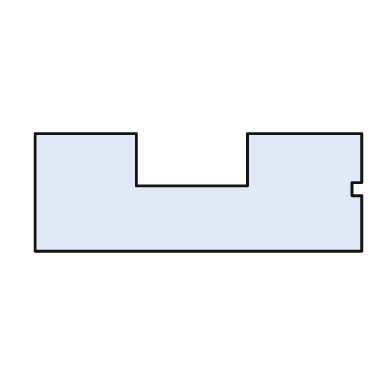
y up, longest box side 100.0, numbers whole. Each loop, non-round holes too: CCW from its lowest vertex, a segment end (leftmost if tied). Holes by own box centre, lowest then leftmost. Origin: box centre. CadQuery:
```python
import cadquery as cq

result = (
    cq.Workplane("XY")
    .moveTo(-50.0, -18.0)
    .lineTo(50.0, -18.0)
    .lineTo(50.0, -1.0)
    .lineTo(47.0, -1.0)
    .lineTo(47.0, 3.0)
    .lineTo(50.0, 3.0)
    .lineTo(50.0, 18.0)
    .lineTo(15.0, 18.0)
    .lineTo(15.0, 2.0)
    .lineTo(-19.0, 2.0)
    .lineTo(-19.0, 18.0)
    .lineTo(-50.0, 18.0)
    .close()
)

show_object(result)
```